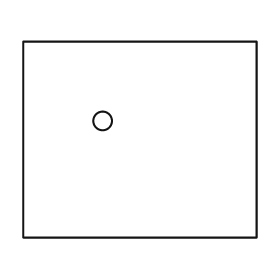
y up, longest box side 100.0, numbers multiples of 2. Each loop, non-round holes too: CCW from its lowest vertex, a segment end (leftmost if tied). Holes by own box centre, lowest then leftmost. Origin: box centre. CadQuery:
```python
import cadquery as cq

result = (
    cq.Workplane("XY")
    .moveTo(-50.0, -42.0)
    .lineTo(50.0, -42.0)
    .lineTo(50.0, 42.0)
    .lineTo(-50.0, 42.0)
    .close()
    .moveTo(-16.0, 8.0)
    .circle(4.0)
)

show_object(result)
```